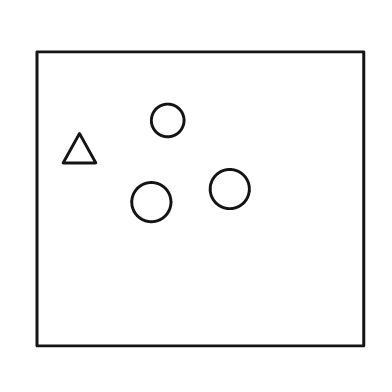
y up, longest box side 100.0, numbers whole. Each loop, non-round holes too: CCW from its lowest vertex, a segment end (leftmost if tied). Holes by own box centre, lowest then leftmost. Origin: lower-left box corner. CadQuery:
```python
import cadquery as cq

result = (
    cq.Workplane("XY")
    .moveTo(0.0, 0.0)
    .lineTo(100.0, 0.0)
    .lineTo(100.0, 90.0)
    .lineTo(0.0, 90.0)
    .close()
    .moveTo(35.0, 44.0)
    .circle(6.0)
    .moveTo(59.0, 48.0)
    .circle(6.0)
    .moveTo(8.0, 56.0)
    .lineTo(18.0, 56.0)
    .lineTo(13.0, 65.0)
    .close()
    .moveTo(40.0, 69.0)
    .circle(5.0)
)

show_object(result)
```